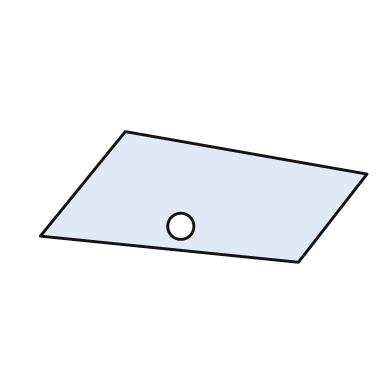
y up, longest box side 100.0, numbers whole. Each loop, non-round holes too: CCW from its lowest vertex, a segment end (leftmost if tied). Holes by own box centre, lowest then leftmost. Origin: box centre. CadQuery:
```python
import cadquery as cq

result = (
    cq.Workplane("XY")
    .moveTo(29.0, -20.0)
    .lineTo(50.0, 7.0)
    .lineTo(-24.0, 20.0)
    .lineTo(-50.0, -12.0)
    .close()
    .moveTo(-7.0, -9.0)
    .circle(4.0)
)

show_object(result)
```